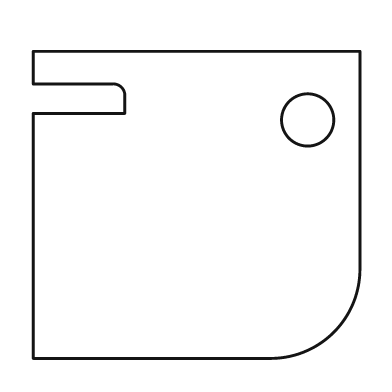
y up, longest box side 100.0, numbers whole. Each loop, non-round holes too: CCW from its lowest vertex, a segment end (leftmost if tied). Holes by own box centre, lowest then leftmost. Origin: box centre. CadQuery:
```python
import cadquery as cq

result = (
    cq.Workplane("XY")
    .moveTo(-50.0, -47.0)
    .lineTo(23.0, -47.0)
    .threePointArc((42.0, -39.0), (50.0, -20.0))
    .lineTo(50.0, 47.0)
    .lineTo(-50.0, 47.0)
    .lineTo(-50.0, 37.0)
    .lineTo(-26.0, 37.0)
    .threePointArc((-23.0, 36.0), (-22.0, 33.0))
    .lineTo(-22.0, 28.0)
    .lineTo(-50.0, 28.0)
    .close()
    .moveTo(34.0, 26.0)
    .circle(8.0)
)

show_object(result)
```